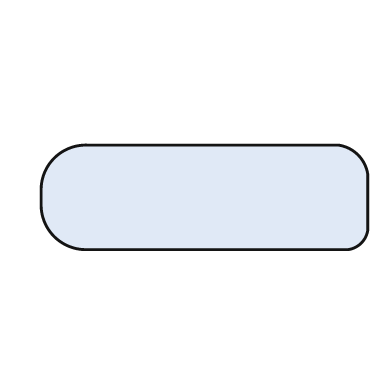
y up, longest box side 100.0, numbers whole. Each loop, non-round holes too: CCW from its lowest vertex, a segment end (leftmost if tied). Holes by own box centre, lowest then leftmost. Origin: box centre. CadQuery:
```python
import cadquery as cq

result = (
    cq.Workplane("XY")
    .moveTo(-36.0, -16.0)
    .lineTo(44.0, -16.0)
    .threePointArc((48.0, -14.0), (50.0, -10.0))
    .lineTo(50.0, 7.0)
    .threePointArc((47.0, 13.0), (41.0, 16.0))
    .lineTo(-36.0, 16.0)
    .threePointArc((-46.0, 12.0), (-50.0, 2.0))
    .lineTo(-50.0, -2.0)
    .threePointArc((-46.0, -12.0), (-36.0, -16.0))
    .close()
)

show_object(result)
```